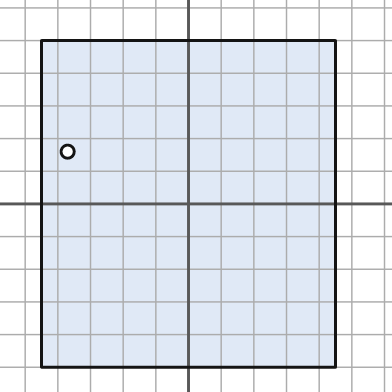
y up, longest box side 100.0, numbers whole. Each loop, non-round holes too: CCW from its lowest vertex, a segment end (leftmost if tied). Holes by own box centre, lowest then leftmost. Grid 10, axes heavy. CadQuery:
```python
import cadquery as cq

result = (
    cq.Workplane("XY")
    .moveTo(-45.0, -50.0)
    .lineTo(45.0, -50.0)
    .lineTo(45.0, 50.0)
    .lineTo(-45.0, 50.0)
    .close()
    .moveTo(-37.0, 16.0)
    .circle(2.0)
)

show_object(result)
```